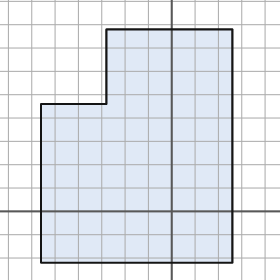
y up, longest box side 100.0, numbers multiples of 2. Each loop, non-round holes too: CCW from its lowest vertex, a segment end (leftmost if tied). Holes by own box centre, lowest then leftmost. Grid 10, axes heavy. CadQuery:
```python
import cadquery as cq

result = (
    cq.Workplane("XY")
    .moveTo(-56.0, -22.0)
    .lineTo(26.0, -22.0)
    .lineTo(26.0, 78.0)
    .lineTo(-28.0, 78.0)
    .lineTo(-28.0, 46.0)
    .lineTo(-56.0, 46.0)
    .close()
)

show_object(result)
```